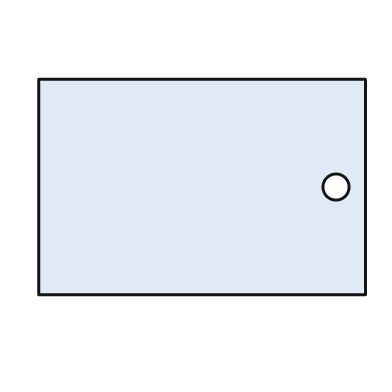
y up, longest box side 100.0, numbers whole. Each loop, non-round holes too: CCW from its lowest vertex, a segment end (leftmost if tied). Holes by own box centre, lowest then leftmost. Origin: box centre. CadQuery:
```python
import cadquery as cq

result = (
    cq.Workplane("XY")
    .moveTo(-50.0, -33.0)
    .lineTo(50.0, -33.0)
    .lineTo(50.0, 33.0)
    .lineTo(-50.0, 33.0)
    .close()
    .moveTo(41.0, 0.0)
    .circle(4.0)
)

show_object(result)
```